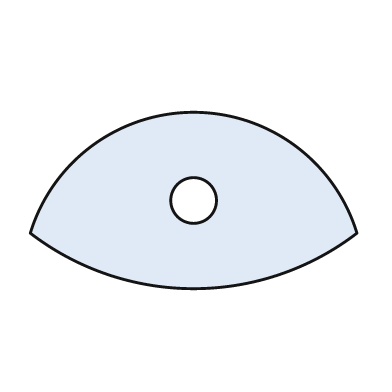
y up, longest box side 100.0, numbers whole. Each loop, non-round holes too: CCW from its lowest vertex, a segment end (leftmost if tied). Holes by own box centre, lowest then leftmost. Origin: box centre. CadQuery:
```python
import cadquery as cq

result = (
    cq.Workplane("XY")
    .moveTo(-50.0, -10.0)
    .threePointArc((0.0, -27.0), (50.0, -10.0))
    .threePointArc((0.0, 27.0), (-50.0, -10.0))
    .close()
    .moveTo(0.0, 0.0)
    .circle(7.0)
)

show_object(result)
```